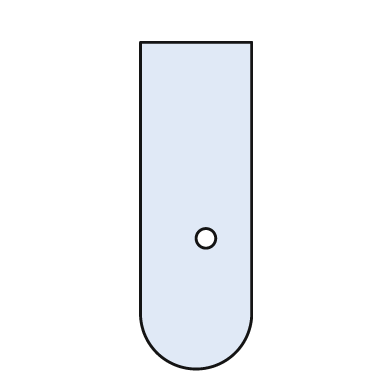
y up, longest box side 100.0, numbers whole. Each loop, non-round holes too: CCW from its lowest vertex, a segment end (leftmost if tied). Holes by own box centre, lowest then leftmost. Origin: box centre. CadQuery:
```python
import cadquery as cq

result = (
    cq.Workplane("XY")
    .moveTo(-17.0, -34.0)
    .threePointArc((0.0, -50.0), (17.0, -34.0))
    .lineTo(17.0, 50.0)
    .lineTo(-17.0, 50.0)
    .close()
    .moveTo(3.0, -10.0)
    .circle(3.0)
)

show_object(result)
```